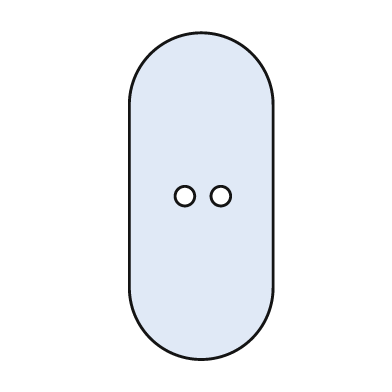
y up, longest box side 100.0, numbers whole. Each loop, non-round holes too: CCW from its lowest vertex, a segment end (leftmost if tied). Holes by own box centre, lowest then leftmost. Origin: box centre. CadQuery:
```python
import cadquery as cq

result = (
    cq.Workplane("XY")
    .moveTo(-22.0, -28.0)
    .threePointArc((0.0, -50.0), (22.0, -28.0))
    .lineTo(22.0, 28.0)
    .threePointArc((0.0, 50.0), (-22.0, 28.0))
    .close()
    .moveTo(-5.0, 0.0)
    .circle(3.0)
    .moveTo(6.0, 0.0)
    .circle(3.0)
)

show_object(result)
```